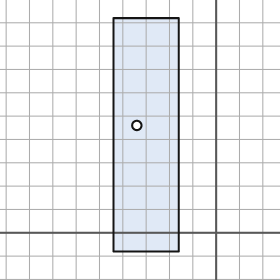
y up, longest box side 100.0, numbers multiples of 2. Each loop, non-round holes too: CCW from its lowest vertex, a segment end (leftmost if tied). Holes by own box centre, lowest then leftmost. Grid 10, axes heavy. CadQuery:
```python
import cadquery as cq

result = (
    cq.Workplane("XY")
    .moveTo(-44.0, -8.0)
    .lineTo(-16.0, -8.0)
    .lineTo(-16.0, 92.0)
    .lineTo(-44.0, 92.0)
    .close()
    .moveTo(-34.0, 46.0)
    .circle(2.0)
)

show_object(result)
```